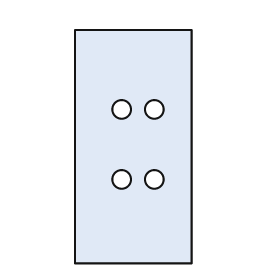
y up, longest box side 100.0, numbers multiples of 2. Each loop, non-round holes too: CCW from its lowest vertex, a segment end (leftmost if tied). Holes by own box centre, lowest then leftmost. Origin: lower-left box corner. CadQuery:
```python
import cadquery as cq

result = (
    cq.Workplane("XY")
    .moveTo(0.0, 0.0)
    .lineTo(50.0, 0.0)
    .lineTo(50.0, 100.0)
    .lineTo(0.0, 100.0)
    .close()
    .moveTo(20.0, 36.0)
    .circle(4.0)
    .moveTo(34.0, 36.0)
    .circle(4.0)
    .moveTo(20.0, 66.0)
    .circle(4.0)
    .moveTo(34.0, 66.0)
    .circle(4.0)
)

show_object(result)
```